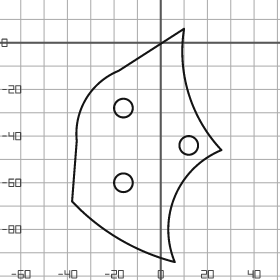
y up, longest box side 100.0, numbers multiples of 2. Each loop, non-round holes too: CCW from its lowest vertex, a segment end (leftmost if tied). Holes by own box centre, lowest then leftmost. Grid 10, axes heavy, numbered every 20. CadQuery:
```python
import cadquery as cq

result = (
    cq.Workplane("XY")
    .moveTo(6.0, -94.0)
    .threePointArc((6.0, -66.0), (26.0, -46.0))
    .threePointArc((12.0, -22.0), (10.0, 6.0))
    .lineTo(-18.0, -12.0)
    .threePointArc((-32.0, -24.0), (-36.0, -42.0))
    .lineTo(-38.0, -68.0)
    .threePointArc((-18.0, -84.0), (6.0, -94.0))
    .close()
    .moveTo(-16.0, -60.0)
    .circle(4.0)
    .moveTo(12.0, -44.0)
    .circle(4.0)
    .moveTo(-16.0, -28.0)
    .circle(4.0)
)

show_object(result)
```